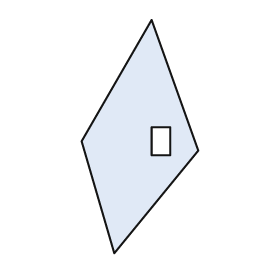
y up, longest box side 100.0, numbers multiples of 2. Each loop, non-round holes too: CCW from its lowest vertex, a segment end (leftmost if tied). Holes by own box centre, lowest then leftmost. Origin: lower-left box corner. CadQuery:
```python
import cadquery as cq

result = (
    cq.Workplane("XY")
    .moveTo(14.0, 0.0)
    .lineTo(50.0, 44.0)
    .lineTo(30.0, 100.0)
    .lineTo(0.0, 48.0)
    .close()
    .moveTo(30.0, 42.0)
    .lineTo(38.0, 42.0)
    .lineTo(38.0, 54.0)
    .lineTo(30.0, 54.0)
    .close()
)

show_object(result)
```